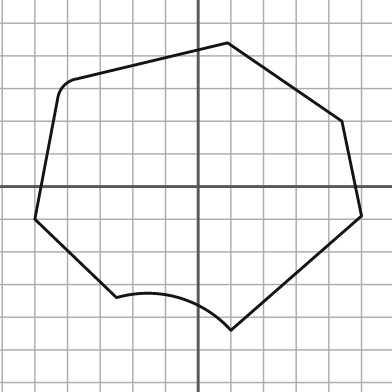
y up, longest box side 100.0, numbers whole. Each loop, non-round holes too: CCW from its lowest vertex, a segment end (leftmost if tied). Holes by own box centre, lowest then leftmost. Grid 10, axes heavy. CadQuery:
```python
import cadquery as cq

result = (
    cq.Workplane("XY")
    .moveTo(10.0, -44.0)
    .lineTo(50.0, -9.0)
    .lineTo(44.0, 20.0)
    .lineTo(9.0, 44.0)
    .lineTo(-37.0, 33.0)
    .threePointArc((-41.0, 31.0), (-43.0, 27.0))
    .lineTo(-50.0, -10.0)
    .lineTo(-25.0, -34.0)
    .threePointArc((-6.0, -34.0), (10.0, -44.0))
    .close()
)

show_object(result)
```